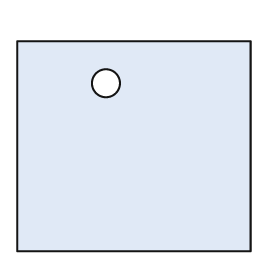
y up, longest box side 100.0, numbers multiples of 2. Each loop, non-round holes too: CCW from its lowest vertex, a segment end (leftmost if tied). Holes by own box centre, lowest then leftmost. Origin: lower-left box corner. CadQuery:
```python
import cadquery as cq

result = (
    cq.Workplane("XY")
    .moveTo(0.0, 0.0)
    .lineTo(100.0, 0.0)
    .lineTo(100.0, 90.0)
    .lineTo(0.0, 90.0)
    .close()
    .moveTo(38.0, 72.0)
    .circle(6.0)
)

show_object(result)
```